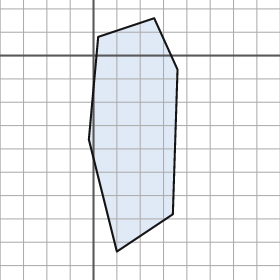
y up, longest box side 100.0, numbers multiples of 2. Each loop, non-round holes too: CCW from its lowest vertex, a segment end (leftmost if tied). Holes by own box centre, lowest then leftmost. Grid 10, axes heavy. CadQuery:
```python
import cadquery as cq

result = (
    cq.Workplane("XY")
    .moveTo(10.0, -84.0)
    .lineTo(34.0, -68.0)
    .lineTo(36.0, -6.0)
    .lineTo(26.0, 16.0)
    .lineTo(2.0, 8.0)
    .lineTo(-2.0, -36.0)
    .close()
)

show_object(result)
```